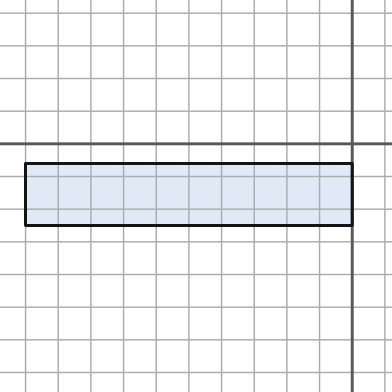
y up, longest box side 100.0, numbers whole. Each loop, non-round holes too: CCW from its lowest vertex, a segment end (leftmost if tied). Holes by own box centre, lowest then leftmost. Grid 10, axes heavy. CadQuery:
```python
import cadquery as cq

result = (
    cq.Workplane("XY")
    .moveTo(-100.0, -25.0)
    .lineTo(0.0, -25.0)
    .lineTo(0.0, -6.0)
    .lineTo(-100.0, -6.0)
    .close()
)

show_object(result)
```